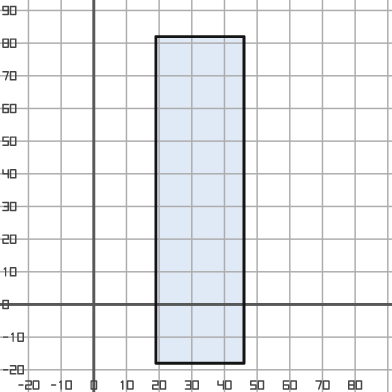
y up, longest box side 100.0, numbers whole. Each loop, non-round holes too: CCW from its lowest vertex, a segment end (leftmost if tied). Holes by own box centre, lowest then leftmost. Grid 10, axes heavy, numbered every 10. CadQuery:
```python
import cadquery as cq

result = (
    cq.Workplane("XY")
    .moveTo(19.0, -18.0)
    .lineTo(46.0, -18.0)
    .lineTo(46.0, 82.0)
    .lineTo(19.0, 82.0)
    .close()
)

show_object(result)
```